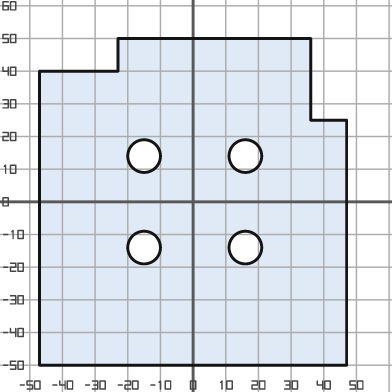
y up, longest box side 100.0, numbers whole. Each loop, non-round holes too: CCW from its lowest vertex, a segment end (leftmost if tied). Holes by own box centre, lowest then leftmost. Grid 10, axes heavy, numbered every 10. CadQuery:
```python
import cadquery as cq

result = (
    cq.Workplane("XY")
    .moveTo(-47.0, -50.0)
    .lineTo(47.0, -50.0)
    .lineTo(47.0, 25.0)
    .lineTo(36.0, 25.0)
    .lineTo(36.0, 50.0)
    .lineTo(-23.0, 50.0)
    .lineTo(-23.0, 40.0)
    .lineTo(-47.0, 40.0)
    .close()
    .moveTo(-15.0, -14.0)
    .circle(5.0)
    .moveTo(16.0, -14.0)
    .circle(5.0)
    .moveTo(-15.0, 14.0)
    .circle(5.0)
    .moveTo(16.0, 14.0)
    .circle(5.0)
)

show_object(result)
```